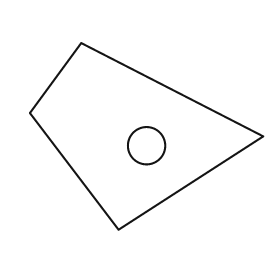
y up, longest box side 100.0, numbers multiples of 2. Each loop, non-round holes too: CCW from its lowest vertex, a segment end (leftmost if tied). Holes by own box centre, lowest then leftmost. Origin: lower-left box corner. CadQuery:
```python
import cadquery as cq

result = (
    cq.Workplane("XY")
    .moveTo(38.0, 0.0)
    .lineTo(100.0, 40.0)
    .lineTo(22.0, 80.0)
    .lineTo(0.0, 50.0)
    .close()
    .moveTo(50.0, 36.0)
    .circle(8.0)
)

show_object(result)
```